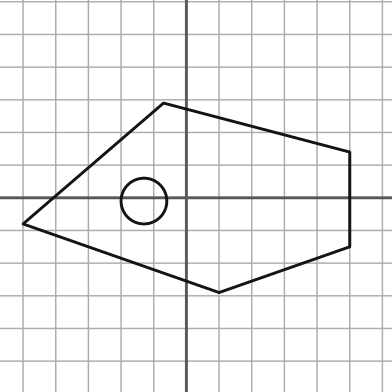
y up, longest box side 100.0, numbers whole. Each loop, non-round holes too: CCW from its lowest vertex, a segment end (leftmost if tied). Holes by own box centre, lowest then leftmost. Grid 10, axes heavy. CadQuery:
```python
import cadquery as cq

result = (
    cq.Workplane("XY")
    .moveTo(10.0, -29.0)
    .lineTo(50.0, -15.0)
    .lineTo(50.0, 14.0)
    .lineTo(-7.0, 29.0)
    .lineTo(-50.0, -8.0)
    .close()
    .moveTo(-13.0, -1.0)
    .circle(7.0)
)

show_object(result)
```